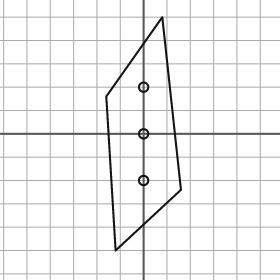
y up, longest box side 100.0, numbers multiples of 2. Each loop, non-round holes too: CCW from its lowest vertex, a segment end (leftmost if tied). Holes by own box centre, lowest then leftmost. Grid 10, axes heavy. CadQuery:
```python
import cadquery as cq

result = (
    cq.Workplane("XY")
    .moveTo(-12.0, -50.0)
    .lineTo(16.0, -24.0)
    .lineTo(8.0, 50.0)
    .lineTo(-16.0, 16.0)
    .close()
    .moveTo(0.0, -20.0)
    .circle(2.0)
    .moveTo(0.0, 0.0)
    .circle(2.0)
    .moveTo(0.0, 20.0)
    .circle(2.0)
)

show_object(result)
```